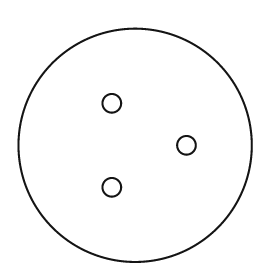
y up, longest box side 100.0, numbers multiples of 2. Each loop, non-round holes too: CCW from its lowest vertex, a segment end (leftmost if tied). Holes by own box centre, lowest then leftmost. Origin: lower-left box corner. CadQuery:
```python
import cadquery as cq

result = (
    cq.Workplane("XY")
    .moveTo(50.0, 50.0)
    .circle(50.0)
    .moveTo(40.0, 32.0)
    .circle(4.0)
    .moveTo(72.0, 50.0)
    .circle(4.0)
    .moveTo(40.0, 68.0)
    .circle(4.0)
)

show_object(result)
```